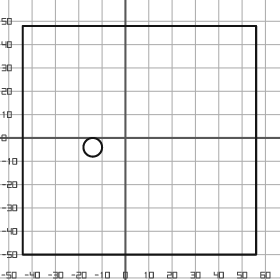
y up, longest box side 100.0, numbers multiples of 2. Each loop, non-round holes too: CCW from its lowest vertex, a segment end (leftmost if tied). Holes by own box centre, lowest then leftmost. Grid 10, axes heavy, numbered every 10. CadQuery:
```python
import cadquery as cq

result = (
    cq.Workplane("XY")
    .moveTo(-44.0, -50.0)
    .lineTo(56.0, -50.0)
    .lineTo(56.0, 48.0)
    .lineTo(-44.0, 48.0)
    .close()
    .moveTo(-14.0, -4.0)
    .circle(4.0)
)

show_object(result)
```